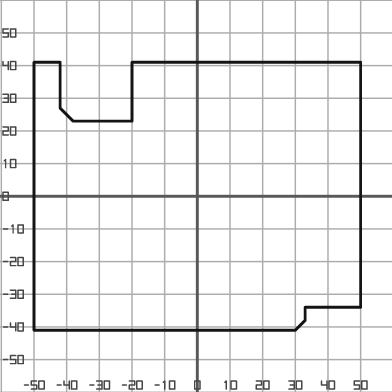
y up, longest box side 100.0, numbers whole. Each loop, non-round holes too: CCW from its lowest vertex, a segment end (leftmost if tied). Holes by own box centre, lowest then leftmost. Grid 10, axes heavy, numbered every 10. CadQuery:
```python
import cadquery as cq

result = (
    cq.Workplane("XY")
    .moveTo(-50.0, -41.0)
    .lineTo(30.0, -41.0)
    .lineTo(33.0, -38.0)
    .lineTo(33.0, -34.0)
    .lineTo(50.0, -34.0)
    .lineTo(50.0, 41.0)
    .lineTo(-20.0, 41.0)
    .lineTo(-20.0, 23.0)
    .lineTo(-38.0, 23.0)
    .lineTo(-42.0, 27.0)
    .lineTo(-42.0, 41.0)
    .lineTo(-50.0, 41.0)
    .close()
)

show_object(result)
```